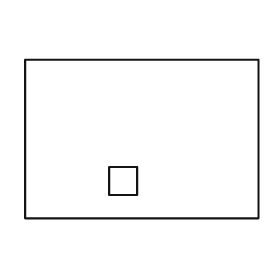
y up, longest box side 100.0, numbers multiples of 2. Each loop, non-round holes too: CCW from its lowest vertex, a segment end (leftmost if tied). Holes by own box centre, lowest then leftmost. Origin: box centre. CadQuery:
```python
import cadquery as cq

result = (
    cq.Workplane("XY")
    .moveTo(-50.0, -34.0)
    .lineTo(50.0, -34.0)
    .lineTo(50.0, 34.0)
    .lineTo(-50.0, 34.0)
    .close()
    .moveTo(-14.0, -24.0)
    .lineTo(-2.0, -24.0)
    .lineTo(-2.0, -12.0)
    .lineTo(-14.0, -12.0)
    .close()
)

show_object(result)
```